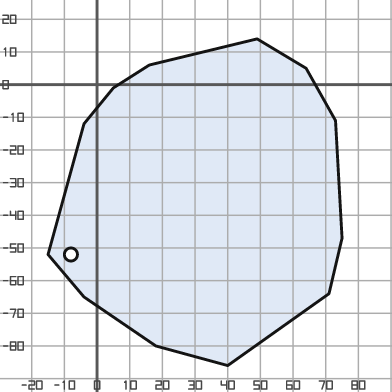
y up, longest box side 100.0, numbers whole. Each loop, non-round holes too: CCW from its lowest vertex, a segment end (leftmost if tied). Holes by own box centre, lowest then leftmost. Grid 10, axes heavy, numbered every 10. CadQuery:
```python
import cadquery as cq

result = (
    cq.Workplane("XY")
    .moveTo(40.0, -86.0)
    .lineTo(71.0, -64.0)
    .lineTo(75.0, -47.0)
    .lineTo(73.0, -11.0)
    .lineTo(64.0, 5.0)
    .lineTo(49.0, 14.0)
    .lineTo(16.0, 6.0)
    .lineTo(5.0, -1.0)
    .lineTo(-4.0, -12.0)
    .lineTo(-15.0, -52.0)
    .lineTo(-4.0, -65.0)
    .lineTo(18.0, -80.0)
    .close()
    .moveTo(-8.0, -52.0)
    .circle(2.0)
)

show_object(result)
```